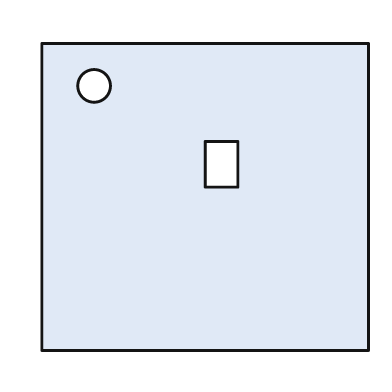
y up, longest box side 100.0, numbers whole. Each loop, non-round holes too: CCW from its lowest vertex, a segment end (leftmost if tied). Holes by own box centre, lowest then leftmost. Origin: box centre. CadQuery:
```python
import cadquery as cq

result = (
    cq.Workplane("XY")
    .moveTo(-50.0, -47.0)
    .lineTo(50.0, -47.0)
    .lineTo(50.0, 47.0)
    .lineTo(-50.0, 47.0)
    .close()
    .moveTo(0.0, 3.0)
    .lineTo(10.0, 3.0)
    .lineTo(10.0, 17.0)
    .lineTo(0.0, 17.0)
    .close()
    .moveTo(-34.0, 34.0)
    .circle(5.0)
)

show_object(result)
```